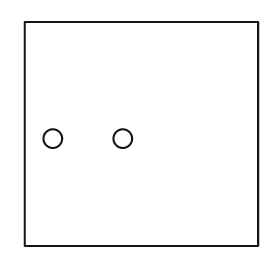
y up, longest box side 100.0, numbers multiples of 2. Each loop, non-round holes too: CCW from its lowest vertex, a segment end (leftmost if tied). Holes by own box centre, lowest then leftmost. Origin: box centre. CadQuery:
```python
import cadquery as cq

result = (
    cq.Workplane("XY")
    .moveTo(-50.0, -48.0)
    .lineTo(50.0, -48.0)
    .lineTo(50.0, 48.0)
    .lineTo(-50.0, 48.0)
    .close()
    .moveTo(-38.0, -2.0)
    .circle(4.0)
    .moveTo(-8.0, -2.0)
    .circle(4.0)
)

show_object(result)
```